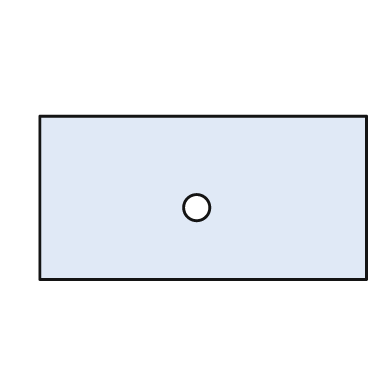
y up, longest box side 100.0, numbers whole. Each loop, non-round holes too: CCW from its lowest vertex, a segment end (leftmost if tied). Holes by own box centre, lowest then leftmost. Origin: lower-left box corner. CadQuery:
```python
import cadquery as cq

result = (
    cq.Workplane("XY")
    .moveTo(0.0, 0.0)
    .lineTo(100.0, 0.0)
    .lineTo(100.0, 50.0)
    .lineTo(0.0, 50.0)
    .close()
    .moveTo(48.0, 22.0)
    .circle(4.0)
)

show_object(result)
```